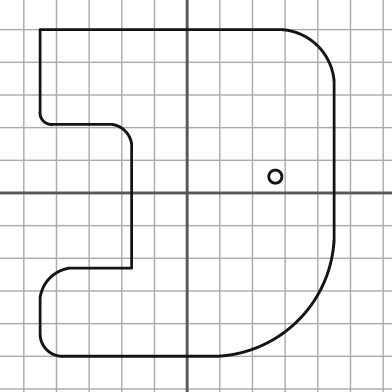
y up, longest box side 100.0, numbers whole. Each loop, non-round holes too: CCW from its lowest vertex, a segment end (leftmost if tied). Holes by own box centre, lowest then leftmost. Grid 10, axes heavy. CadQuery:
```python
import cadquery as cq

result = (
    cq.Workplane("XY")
    .moveTo(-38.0, -50.0)
    .lineTo(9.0, -50.0)
    .threePointArc((34.0, -39.0), (45.0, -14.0))
    .lineTo(45.0, 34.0)
    .threePointArc((40.0, 45.0), (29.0, 50.0))
    .lineTo(-45.0, 50.0)
    .lineTo(-45.0, 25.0)
    .threePointArc((-44.0, 22.0), (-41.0, 21.0))
    .lineTo(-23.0, 21.0)
    .threePointArc((-19.0, 19.0), (-17.0, 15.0))
    .lineTo(-17.0, -23.0)
    .lineTo(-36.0, -23.0)
    .threePointArc((-42.0, -26.0), (-45.0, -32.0))
    .lineTo(-45.0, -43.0)
    .threePointArc((-43.0, -48.0), (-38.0, -50.0))
    .close()
    .moveTo(27.0, 5.0)
    .circle(2.0)
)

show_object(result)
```